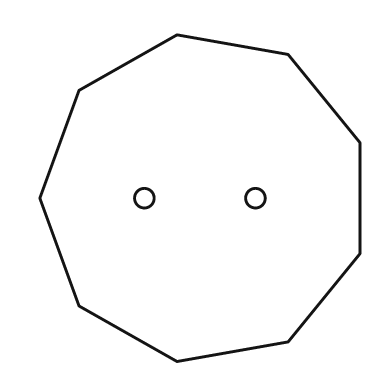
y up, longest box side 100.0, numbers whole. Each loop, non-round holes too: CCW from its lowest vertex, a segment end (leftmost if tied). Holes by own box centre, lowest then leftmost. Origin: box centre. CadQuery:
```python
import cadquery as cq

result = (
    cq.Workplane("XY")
    .moveTo(-7.0, -50.0)
    .lineTo(27.0, -44.0)
    .lineTo(49.0, -17.0)
    .lineTo(49.0, 17.0)
    .lineTo(27.0, 44.0)
    .lineTo(-7.0, 50.0)
    .lineTo(-37.0, 33.0)
    .lineTo(-49.0, 0.0)
    .lineTo(-37.0, -33.0)
    .close()
    .moveTo(-17.0, 0.0)
    .circle(3.0)
    .moveTo(17.0, 0.0)
    .circle(3.0)
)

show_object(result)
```